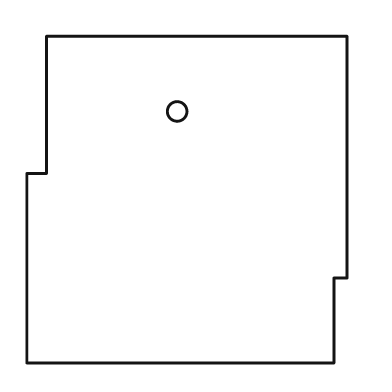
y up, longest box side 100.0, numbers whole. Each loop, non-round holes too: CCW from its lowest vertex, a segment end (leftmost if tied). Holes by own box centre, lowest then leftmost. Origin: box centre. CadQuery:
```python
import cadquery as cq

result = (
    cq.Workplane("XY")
    .moveTo(-49.0, -50.0)
    .lineTo(45.0, -50.0)
    .lineTo(45.0, -24.0)
    .lineTo(49.0, -24.0)
    .lineTo(49.0, 50.0)
    .lineTo(-43.0, 50.0)
    .lineTo(-43.0, 8.0)
    .lineTo(-49.0, 8.0)
    .close()
    .moveTo(-3.0, 27.0)
    .circle(3.0)
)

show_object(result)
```